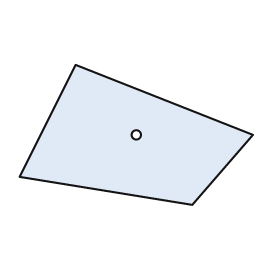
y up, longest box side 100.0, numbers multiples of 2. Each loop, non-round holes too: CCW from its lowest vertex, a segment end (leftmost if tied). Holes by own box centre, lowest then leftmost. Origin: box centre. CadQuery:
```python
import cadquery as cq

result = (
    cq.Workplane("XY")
    .moveTo(24.0, -30.0)
    .lineTo(50.0, 0.0)
    .lineTo(-26.0, 30.0)
    .lineTo(-50.0, -18.0)
    .close()
    .moveTo(0.0, 0.0)
    .circle(2.0)
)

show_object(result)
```